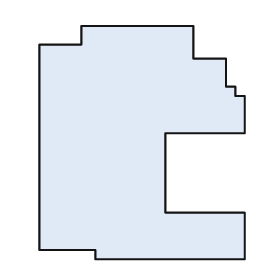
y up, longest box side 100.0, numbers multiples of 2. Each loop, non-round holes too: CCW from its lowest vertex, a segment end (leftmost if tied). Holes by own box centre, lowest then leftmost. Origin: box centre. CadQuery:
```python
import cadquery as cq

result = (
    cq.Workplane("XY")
    .moveTo(-20.0, -50.0)
    .lineTo(44.0, -50.0)
    .lineTo(44.0, -30.0)
    .lineTo(10.0, -30.0)
    .lineTo(10.0, 4.0)
    .lineTo(44.0, 4.0)
    .lineTo(44.0, 20.0)
    .lineTo(40.0, 20.0)
    .lineTo(40.0, 24.0)
    .lineTo(36.0, 24.0)
    .lineTo(36.0, 36.0)
    .lineTo(22.0, 36.0)
    .lineTo(22.0, 50.0)
    .lineTo(-26.0, 50.0)
    .lineTo(-26.0, 42.0)
    .lineTo(-44.0, 42.0)
    .lineTo(-44.0, -46.0)
    .lineTo(-20.0, -46.0)
    .close()
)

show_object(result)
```